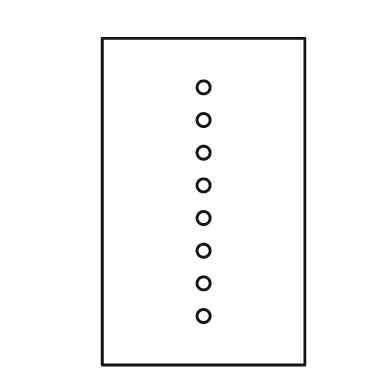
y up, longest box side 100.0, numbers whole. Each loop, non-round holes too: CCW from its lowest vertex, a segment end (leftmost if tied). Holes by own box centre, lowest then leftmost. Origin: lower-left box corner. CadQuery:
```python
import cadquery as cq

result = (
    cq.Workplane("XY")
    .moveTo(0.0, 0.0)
    .lineTo(62.0, 0.0)
    .lineTo(62.0, 100.0)
    .lineTo(0.0, 100.0)
    .close()
    .moveTo(31.0, 15.0)
    .circle(2.0)
    .moveTo(31.0, 25.0)
    .circle(2.0)
    .moveTo(31.0, 35.0)
    .circle(2.0)
    .moveTo(31.0, 45.0)
    .circle(2.0)
    .moveTo(31.0, 55.0)
    .circle(2.0)
    .moveTo(31.0, 65.0)
    .circle(2.0)
    .moveTo(31.0, 75.0)
    .circle(2.0)
    .moveTo(31.0, 85.0)
    .circle(2.0)
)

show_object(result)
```